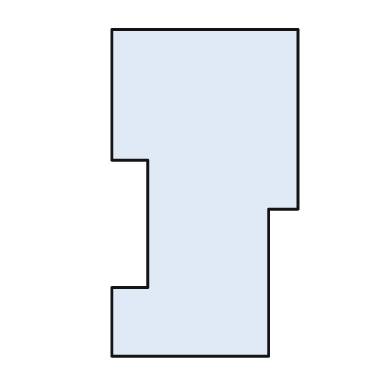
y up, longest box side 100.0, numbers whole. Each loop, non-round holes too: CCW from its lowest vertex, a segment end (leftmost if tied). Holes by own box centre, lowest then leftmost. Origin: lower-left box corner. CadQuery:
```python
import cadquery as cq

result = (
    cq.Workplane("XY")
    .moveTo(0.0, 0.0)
    .lineTo(48.0, 0.0)
    .lineTo(48.0, 45.0)
    .lineTo(57.0, 45.0)
    .lineTo(57.0, 100.0)
    .lineTo(0.0, 100.0)
    .lineTo(0.0, 60.0)
    .lineTo(11.0, 60.0)
    .lineTo(11.0, 21.0)
    .lineTo(0.0, 21.0)
    .close()
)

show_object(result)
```